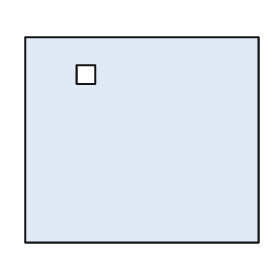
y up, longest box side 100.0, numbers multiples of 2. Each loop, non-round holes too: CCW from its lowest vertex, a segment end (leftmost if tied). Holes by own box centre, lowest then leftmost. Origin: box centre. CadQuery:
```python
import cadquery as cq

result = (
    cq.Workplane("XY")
    .moveTo(-50.0, -44.0)
    .lineTo(50.0, -44.0)
    .lineTo(50.0, 44.0)
    .lineTo(-50.0, 44.0)
    .close()
    .moveTo(-28.0, 24.0)
    .lineTo(-20.0, 24.0)
    .lineTo(-20.0, 32.0)
    .lineTo(-28.0, 32.0)
    .close()
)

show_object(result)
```